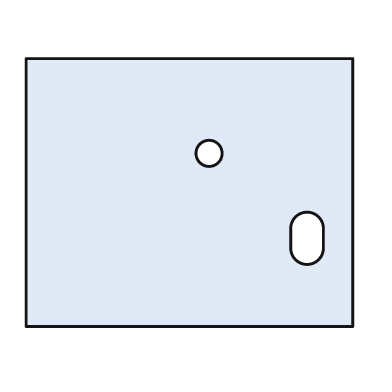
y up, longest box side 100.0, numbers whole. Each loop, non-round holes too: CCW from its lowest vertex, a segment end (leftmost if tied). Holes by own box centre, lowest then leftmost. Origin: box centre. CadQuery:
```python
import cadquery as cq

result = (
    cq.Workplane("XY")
    .moveTo(-50.0, -41.0)
    .lineTo(50.0, -41.0)
    .lineTo(50.0, 41.0)
    .lineTo(-50.0, 41.0)
    .close()
    .moveTo(31.0, -17.0)
    .threePointArc((36.0, -22.0), (41.0, -17.0))
    .lineTo(41.0, -11.0)
    .threePointArc((36.0, -6.0), (31.0, -11.0))
    .close()
    .moveTo(6.0, 12.0)
    .circle(4.0)
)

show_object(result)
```